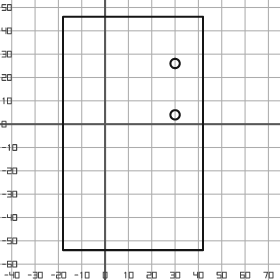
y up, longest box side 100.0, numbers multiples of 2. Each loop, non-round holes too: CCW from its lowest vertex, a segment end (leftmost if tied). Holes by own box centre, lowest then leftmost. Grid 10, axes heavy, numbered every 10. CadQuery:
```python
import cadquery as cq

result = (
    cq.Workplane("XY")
    .moveTo(-18.0, -54.0)
    .lineTo(42.0, -54.0)
    .lineTo(42.0, 46.0)
    .lineTo(-18.0, 46.0)
    .close()
    .moveTo(30.0, 4.0)
    .circle(2.0)
    .moveTo(30.0, 26.0)
    .circle(2.0)
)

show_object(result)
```